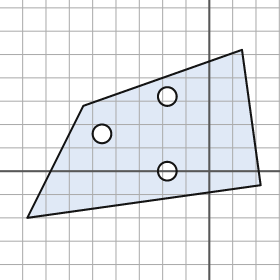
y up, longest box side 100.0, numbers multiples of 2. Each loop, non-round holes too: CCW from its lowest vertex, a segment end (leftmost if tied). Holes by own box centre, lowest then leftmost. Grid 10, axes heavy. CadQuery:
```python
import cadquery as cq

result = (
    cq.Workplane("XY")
    .moveTo(-78.0, -20.0)
    .lineTo(22.0, -6.0)
    .lineTo(14.0, 52.0)
    .lineTo(-54.0, 28.0)
    .close()
    .moveTo(-18.0, 0.0)
    .circle(4.0)
    .moveTo(-46.0, 16.0)
    .circle(4.0)
    .moveTo(-18.0, 32.0)
    .circle(4.0)
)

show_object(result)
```